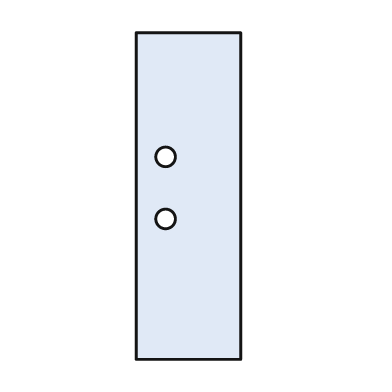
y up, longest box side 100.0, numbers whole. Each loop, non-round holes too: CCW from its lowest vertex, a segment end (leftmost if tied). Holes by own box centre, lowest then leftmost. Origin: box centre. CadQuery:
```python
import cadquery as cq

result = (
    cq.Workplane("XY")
    .moveTo(-16.0, -50.0)
    .lineTo(16.0, -50.0)
    .lineTo(16.0, 50.0)
    .lineTo(-16.0, 50.0)
    .close()
    .moveTo(-7.0, -7.0)
    .circle(3.0)
    .moveTo(-7.0, 12.0)
    .circle(3.0)
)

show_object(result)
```